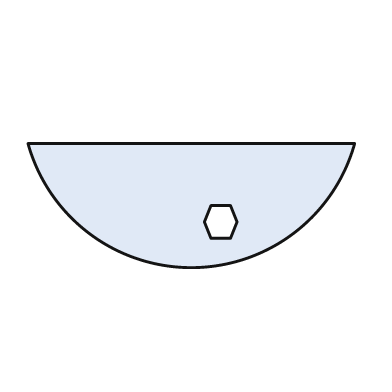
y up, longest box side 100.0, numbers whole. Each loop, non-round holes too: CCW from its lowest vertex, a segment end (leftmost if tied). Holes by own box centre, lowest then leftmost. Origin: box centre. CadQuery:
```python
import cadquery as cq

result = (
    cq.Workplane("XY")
    .moveTo(-50.0, 19.0)
    .threePointArc((0.0, -19.0), (50.0, 19.0))
    .close()
    .moveTo(6.0, -10.0)
    .lineTo(12.0, -10.0)
    .lineTo(14.0, -5.0)
    .lineTo(12.0, 0.0)
    .lineTo(6.0, 0.0)
    .lineTo(4.0, -5.0)
    .close()
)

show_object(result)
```